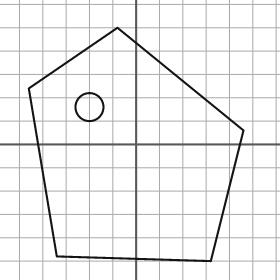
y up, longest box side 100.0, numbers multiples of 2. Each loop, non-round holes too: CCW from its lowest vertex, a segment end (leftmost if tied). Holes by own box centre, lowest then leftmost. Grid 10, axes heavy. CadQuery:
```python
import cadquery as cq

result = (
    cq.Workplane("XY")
    .moveTo(32.0, -50.0)
    .lineTo(46.0, 6.0)
    .lineTo(-8.0, 50.0)
    .lineTo(-46.0, 24.0)
    .lineTo(-34.0, -48.0)
    .close()
    .moveTo(-20.0, 16.0)
    .circle(6.0)
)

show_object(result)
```